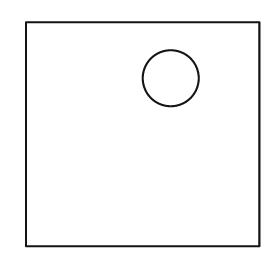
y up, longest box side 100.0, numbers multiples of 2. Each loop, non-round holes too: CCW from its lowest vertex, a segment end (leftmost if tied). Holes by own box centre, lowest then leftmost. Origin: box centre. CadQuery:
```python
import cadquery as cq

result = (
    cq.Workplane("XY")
    .moveTo(-50.0, -48.0)
    .lineTo(50.0, -48.0)
    .lineTo(50.0, 48.0)
    .lineTo(-50.0, 48.0)
    .close()
    .moveTo(12.0, 24.0)
    .circle(12.0)
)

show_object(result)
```